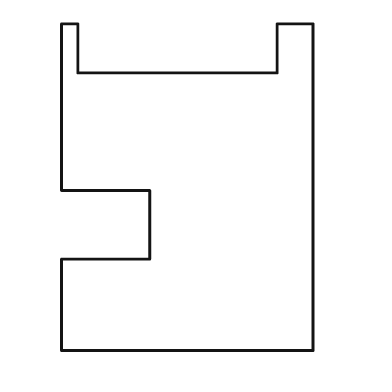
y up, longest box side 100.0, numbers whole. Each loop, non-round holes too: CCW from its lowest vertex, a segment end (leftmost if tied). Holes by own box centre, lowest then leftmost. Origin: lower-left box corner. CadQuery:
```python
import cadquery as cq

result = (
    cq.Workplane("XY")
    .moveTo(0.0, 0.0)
    .lineTo(77.0, 0.0)
    .lineTo(77.0, 100.0)
    .lineTo(66.0, 100.0)
    .lineTo(66.0, 85.0)
    .lineTo(5.0, 85.0)
    .lineTo(5.0, 100.0)
    .lineTo(0.0, 100.0)
    .lineTo(0.0, 49.0)
    .lineTo(27.0, 49.0)
    .lineTo(27.0, 28.0)
    .lineTo(0.0, 28.0)
    .close()
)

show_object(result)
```